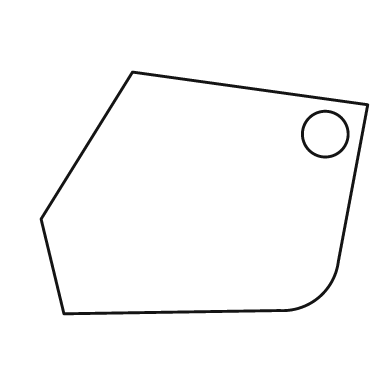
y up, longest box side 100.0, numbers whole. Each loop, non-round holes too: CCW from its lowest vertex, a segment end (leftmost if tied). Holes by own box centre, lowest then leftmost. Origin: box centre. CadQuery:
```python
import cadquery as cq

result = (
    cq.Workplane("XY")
    .moveTo(-43.0, -37.0)
    .lineTo(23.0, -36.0)
    .threePointArc((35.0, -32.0), (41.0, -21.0))
    .lineTo(50.0, 27.0)
    .lineTo(-22.0, 37.0)
    .lineTo(-50.0, -8.0)
    .close()
    .moveTo(37.0, 18.0)
    .circle(7.0)
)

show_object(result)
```